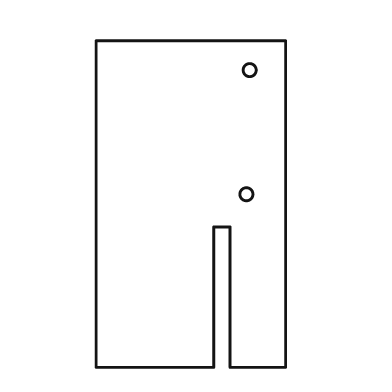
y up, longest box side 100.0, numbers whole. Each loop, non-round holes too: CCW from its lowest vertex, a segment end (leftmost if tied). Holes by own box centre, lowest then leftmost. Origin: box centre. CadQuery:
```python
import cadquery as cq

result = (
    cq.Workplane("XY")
    .moveTo(-29.0, -50.0)
    .lineTo(7.0, -50.0)
    .lineTo(7.0, -7.0)
    .lineTo(12.0, -7.0)
    .lineTo(12.0, -50.0)
    .lineTo(29.0, -50.0)
    .lineTo(29.0, 50.0)
    .lineTo(-29.0, 50.0)
    .close()
    .moveTo(17.0, 3.0)
    .circle(2.0)
    .moveTo(18.0, 41.0)
    .circle(2.0)
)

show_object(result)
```